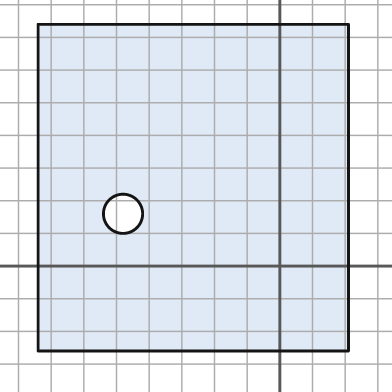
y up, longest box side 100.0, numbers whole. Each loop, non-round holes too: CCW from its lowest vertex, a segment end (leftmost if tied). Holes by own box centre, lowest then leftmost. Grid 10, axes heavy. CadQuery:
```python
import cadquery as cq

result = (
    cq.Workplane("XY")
    .moveTo(-74.0, -26.0)
    .lineTo(21.0, -26.0)
    .lineTo(21.0, 74.0)
    .lineTo(-74.0, 74.0)
    .close()
    .moveTo(-48.0, 16.0)
    .circle(6.0)
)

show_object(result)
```